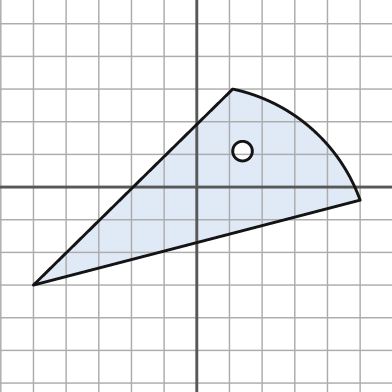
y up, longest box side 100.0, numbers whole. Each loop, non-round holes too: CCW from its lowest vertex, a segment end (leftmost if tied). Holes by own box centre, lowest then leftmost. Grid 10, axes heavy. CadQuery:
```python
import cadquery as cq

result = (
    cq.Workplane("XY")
    .moveTo(-50.0, -30.0)
    .lineTo(50.0, -4.0)
    .threePointArc((35.0, 18.0), (11.0, 30.0))
    .close()
    .moveTo(14.0, 11.0)
    .circle(3.0)
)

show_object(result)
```